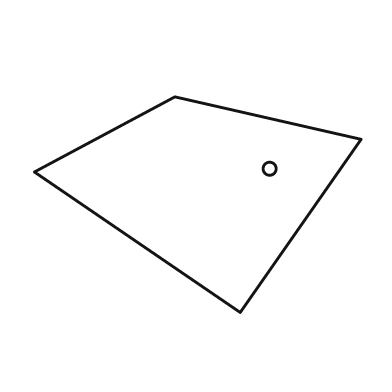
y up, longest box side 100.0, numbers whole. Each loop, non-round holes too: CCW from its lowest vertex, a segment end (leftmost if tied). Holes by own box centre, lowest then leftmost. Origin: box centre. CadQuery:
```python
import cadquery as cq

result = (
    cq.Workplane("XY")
    .moveTo(13.0, -33.0)
    .lineTo(50.0, 20.0)
    .lineTo(-7.0, 33.0)
    .lineTo(-50.0, 10.0)
    .close()
    .moveTo(22.0, 11.0)
    .circle(2.0)
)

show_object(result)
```